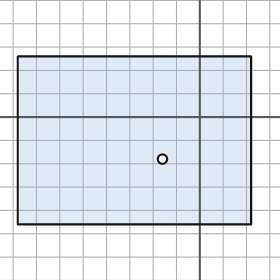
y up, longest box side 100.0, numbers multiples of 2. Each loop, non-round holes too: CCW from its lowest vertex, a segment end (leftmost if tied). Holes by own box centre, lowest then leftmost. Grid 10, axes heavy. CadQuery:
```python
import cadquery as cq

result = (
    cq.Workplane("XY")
    .moveTo(-78.0, -46.0)
    .lineTo(22.0, -46.0)
    .lineTo(22.0, 26.0)
    .lineTo(-78.0, 26.0)
    .close()
    .moveTo(-16.0, -18.0)
    .circle(2.0)
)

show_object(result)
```